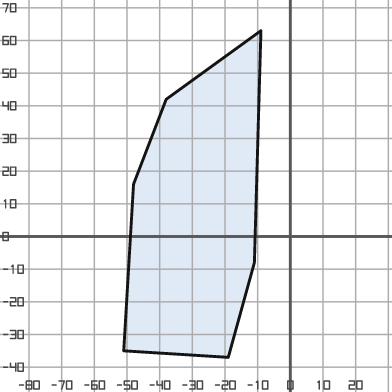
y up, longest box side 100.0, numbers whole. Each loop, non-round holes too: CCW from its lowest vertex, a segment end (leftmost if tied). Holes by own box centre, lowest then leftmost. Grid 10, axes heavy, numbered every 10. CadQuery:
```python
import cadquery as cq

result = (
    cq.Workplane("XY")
    .moveTo(-19.0, -37.0)
    .lineTo(-11.0, -8.0)
    .lineTo(-9.0, 63.0)
    .lineTo(-38.0, 42.0)
    .lineTo(-48.0, 16.0)
    .lineTo(-51.0, -35.0)
    .close()
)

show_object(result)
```